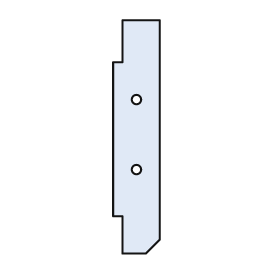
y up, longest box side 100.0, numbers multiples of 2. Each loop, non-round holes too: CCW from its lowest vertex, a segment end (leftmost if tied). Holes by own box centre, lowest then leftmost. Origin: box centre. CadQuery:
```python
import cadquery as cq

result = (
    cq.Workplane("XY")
    .moveTo(-6.0, -50.0)
    .lineTo(4.0, -50.0)
    .lineTo(10.0, -44.0)
    .lineTo(10.0, 50.0)
    .lineTo(-6.0, 50.0)
    .lineTo(-6.0, 32.0)
    .lineTo(-10.0, 32.0)
    .lineTo(-10.0, -34.0)
    .lineTo(-6.0, -34.0)
    .close()
    .moveTo(0.0, -14.0)
    .circle(2.0)
    .moveTo(0.0, 16.0)
    .circle(2.0)
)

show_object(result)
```